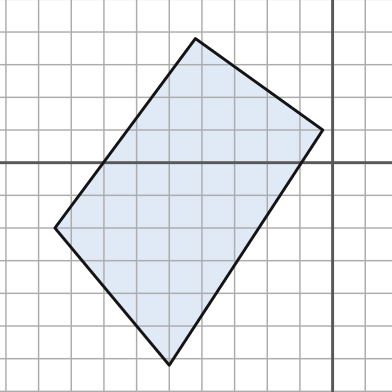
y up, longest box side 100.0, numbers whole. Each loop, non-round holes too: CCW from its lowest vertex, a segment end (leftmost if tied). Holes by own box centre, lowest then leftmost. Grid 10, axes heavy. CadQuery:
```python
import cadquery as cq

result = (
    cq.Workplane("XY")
    .moveTo(-50.0, -62.0)
    .lineTo(-3.0, 10.0)
    .lineTo(-42.0, 38.0)
    .lineTo(-85.0, -20.0)
    .close()
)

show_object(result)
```